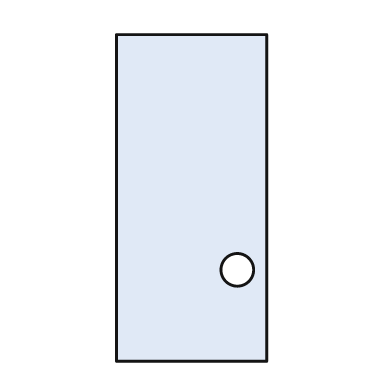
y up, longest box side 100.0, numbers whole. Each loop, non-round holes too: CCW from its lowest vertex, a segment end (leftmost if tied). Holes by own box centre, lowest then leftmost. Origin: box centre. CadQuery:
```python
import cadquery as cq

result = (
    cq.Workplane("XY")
    .moveTo(-23.0, -50.0)
    .lineTo(23.0, -50.0)
    .lineTo(23.0, 50.0)
    .lineTo(-23.0, 50.0)
    .close()
    .moveTo(14.0, -22.0)
    .circle(5.0)
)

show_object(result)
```